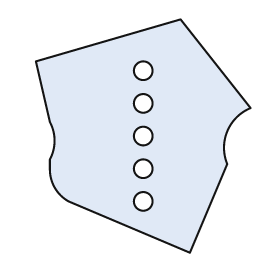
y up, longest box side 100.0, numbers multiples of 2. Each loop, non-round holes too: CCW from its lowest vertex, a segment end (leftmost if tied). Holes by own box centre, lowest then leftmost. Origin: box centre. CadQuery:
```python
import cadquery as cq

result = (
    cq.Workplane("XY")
    .moveTo(20.0, -50.0)
    .lineTo(36.0, -12.0)
    .threePointArc((36.0, 2.0), (46.0, 12.0))
    .lineTo(16.0, 50.0)
    .lineTo(-46.0, 32.0)
    .lineTo(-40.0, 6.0)
    .threePointArc((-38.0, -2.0), (-40.0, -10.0))
    .lineTo(-40.0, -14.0)
    .threePointArc((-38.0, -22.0), (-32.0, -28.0))
    .close()
    .moveTo(0.0, -28.0)
    .circle(4.0)
    .moveTo(0.0, -14.0)
    .circle(4.0)
    .moveTo(0.0, 0.0)
    .circle(4.0)
    .moveTo(0.0, 14.0)
    .circle(4.0)
    .moveTo(0.0, 28.0)
    .circle(4.0)
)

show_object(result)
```